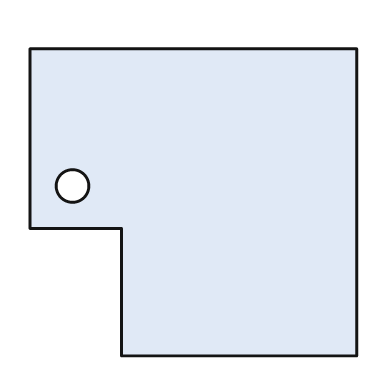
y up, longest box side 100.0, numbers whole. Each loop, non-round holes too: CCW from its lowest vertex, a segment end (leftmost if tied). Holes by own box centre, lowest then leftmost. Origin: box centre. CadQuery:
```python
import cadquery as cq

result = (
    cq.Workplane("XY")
    .moveTo(-22.0, -47.0)
    .lineTo(50.0, -47.0)
    .lineTo(50.0, 47.0)
    .lineTo(-50.0, 47.0)
    .lineTo(-50.0, -8.0)
    .lineTo(-22.0, -8.0)
    .close()
    .moveTo(-37.0, 5.0)
    .circle(5.0)
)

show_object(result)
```